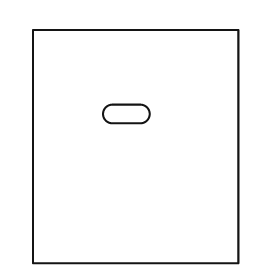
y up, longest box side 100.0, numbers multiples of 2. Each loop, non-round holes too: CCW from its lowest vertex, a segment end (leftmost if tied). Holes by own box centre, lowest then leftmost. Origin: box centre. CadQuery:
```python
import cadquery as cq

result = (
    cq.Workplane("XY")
    .moveTo(-44.0, -50.0)
    .lineTo(44.0, -50.0)
    .lineTo(44.0, 50.0)
    .lineTo(-44.0, 50.0)
    .close()
    .moveTo(-10.0, 10.0)
    .lineTo(2.0, 10.0)
    .threePointArc((6.0, 14.0), (2.0, 18.0))
    .lineTo(-10.0, 18.0)
    .threePointArc((-14.0, 14.0), (-10.0, 10.0))
    .close()
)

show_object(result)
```